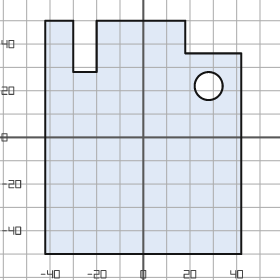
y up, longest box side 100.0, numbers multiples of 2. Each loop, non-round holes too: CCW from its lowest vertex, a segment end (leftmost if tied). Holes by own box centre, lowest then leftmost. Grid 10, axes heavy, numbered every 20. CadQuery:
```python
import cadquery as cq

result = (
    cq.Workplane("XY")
    .moveTo(-42.0, -50.0)
    .lineTo(42.0, -50.0)
    .lineTo(42.0, 36.0)
    .lineTo(18.0, 36.0)
    .lineTo(18.0, 50.0)
    .lineTo(-20.0, 50.0)
    .lineTo(-20.0, 28.0)
    .lineTo(-30.0, 28.0)
    .lineTo(-30.0, 50.0)
    .lineTo(-42.0, 50.0)
    .close()
    .moveTo(28.0, 22.0)
    .circle(6.0)
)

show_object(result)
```